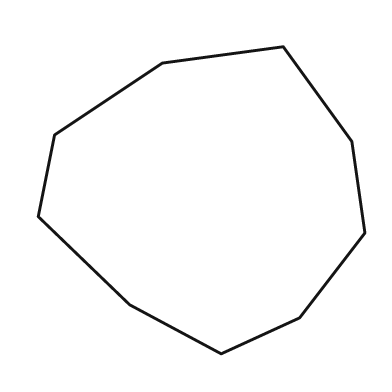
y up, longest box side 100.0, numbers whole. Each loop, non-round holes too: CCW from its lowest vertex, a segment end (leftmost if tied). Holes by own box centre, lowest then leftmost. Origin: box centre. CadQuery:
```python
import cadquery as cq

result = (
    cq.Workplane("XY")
    .moveTo(6.0, -47.0)
    .lineTo(30.0, -36.0)
    .lineTo(50.0, -10.0)
    .lineTo(46.0, 18.0)
    .lineTo(25.0, 47.0)
    .lineTo(-12.0, 42.0)
    .lineTo(-45.0, 20.0)
    .lineTo(-50.0, -5.0)
    .lineTo(-22.0, -32.0)
    .close()
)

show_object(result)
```